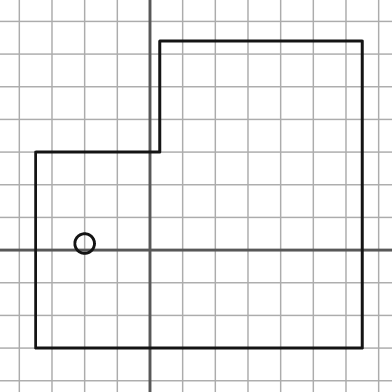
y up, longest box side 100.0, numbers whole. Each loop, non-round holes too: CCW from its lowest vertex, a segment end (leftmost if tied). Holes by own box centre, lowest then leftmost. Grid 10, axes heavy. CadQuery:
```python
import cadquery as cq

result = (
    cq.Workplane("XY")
    .moveTo(-35.0, -30.0)
    .lineTo(65.0, -30.0)
    .lineTo(65.0, 64.0)
    .lineTo(3.0, 64.0)
    .lineTo(3.0, 30.0)
    .lineTo(-35.0, 30.0)
    .close()
    .moveTo(-20.0, 2.0)
    .circle(3.0)
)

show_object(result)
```